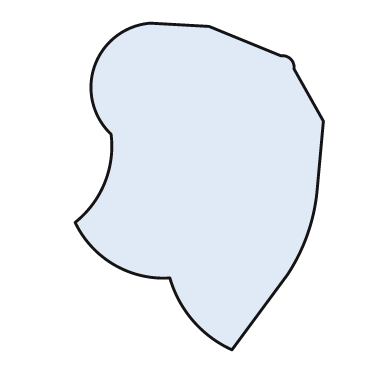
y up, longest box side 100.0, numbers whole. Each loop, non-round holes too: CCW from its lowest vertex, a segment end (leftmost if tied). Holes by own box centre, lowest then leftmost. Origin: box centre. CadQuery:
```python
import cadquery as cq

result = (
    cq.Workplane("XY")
    .moveTo(10.0, -50.0)
    .lineTo(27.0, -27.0)
    .threePointArc((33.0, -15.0), (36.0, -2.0))
    .lineTo(38.0, 20.0)
    .lineTo(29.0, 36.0)
    .threePointArc((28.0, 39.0), (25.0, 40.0))
    .lineTo(3.0, 49.0)
    .lineTo(-15.0, 50.0)
    .threePointArc((-32.0, 37.0), (-27.0, 16.0))
    .threePointArc((-29.0, 1.0), (-38.0, -11.0))
    .threePointArc((-26.0, -24.0), (-9.0, -28.0))
    .threePointArc((-2.0, -41.0), (10.0, -50.0))
    .close()
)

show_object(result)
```